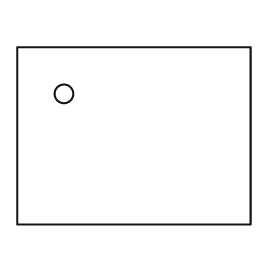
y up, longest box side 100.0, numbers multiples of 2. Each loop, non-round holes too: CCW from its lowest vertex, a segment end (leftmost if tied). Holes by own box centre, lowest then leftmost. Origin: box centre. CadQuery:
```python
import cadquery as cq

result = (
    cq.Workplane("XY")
    .moveTo(-50.0, -38.0)
    .lineTo(50.0, -38.0)
    .lineTo(50.0, 38.0)
    .lineTo(-50.0, 38.0)
    .close()
    .moveTo(-30.0, 18.0)
    .circle(4.0)
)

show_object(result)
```